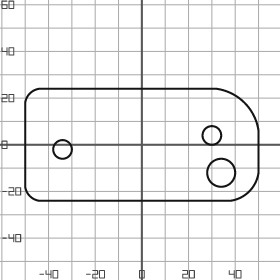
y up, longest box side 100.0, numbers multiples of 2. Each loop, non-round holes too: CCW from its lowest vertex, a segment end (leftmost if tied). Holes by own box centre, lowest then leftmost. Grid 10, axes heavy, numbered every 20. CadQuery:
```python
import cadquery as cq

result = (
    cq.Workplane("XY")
    .moveTo(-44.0, -24.0)
    .lineTo(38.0, -24.0)
    .threePointArc((46.0, -20.0), (50.0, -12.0))
    .lineTo(50.0, 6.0)
    .threePointArc((44.0, 18.0), (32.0, 24.0))
    .lineTo(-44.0, 24.0)
    .threePointArc((-48.0, 22.0), (-50.0, 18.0))
    .lineTo(-50.0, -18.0)
    .threePointArc((-48.0, -22.0), (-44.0, -24.0))
    .close()
    .moveTo(34.0, -12.0)
    .circle(6.0)
    .moveTo(-34.0, -2.0)
    .circle(4.0)
    .moveTo(30.0, 4.0)
    .circle(4.0)
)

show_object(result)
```